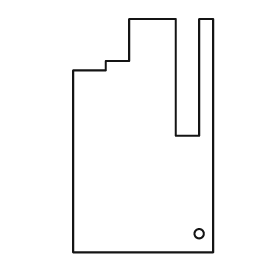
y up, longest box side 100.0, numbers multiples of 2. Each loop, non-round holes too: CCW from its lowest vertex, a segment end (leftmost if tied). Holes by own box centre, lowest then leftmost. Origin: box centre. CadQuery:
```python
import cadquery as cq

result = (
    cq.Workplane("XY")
    .moveTo(-30.0, -50.0)
    .lineTo(30.0, -50.0)
    .lineTo(30.0, 50.0)
    .lineTo(24.0, 50.0)
    .lineTo(24.0, 0.0)
    .lineTo(14.0, 0.0)
    .lineTo(14.0, 50.0)
    .lineTo(-6.0, 50.0)
    .lineTo(-6.0, 32.0)
    .lineTo(-16.0, 32.0)
    .lineTo(-16.0, 28.0)
    .lineTo(-30.0, 28.0)
    .close()
    .moveTo(24.0, -42.0)
    .circle(2.0)
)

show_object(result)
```